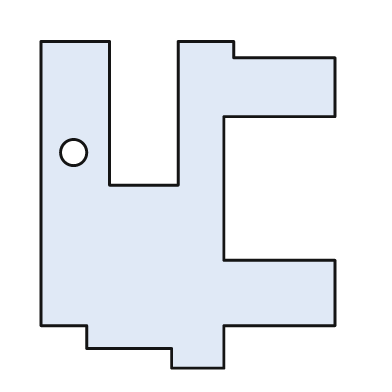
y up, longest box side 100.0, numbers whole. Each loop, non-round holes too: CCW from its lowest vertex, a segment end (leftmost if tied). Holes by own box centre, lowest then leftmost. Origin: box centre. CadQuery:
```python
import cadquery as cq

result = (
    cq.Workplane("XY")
    .moveTo(-5.0, -50.0)
    .lineTo(11.0, -50.0)
    .lineTo(11.0, -37.0)
    .lineTo(45.0, -37.0)
    .lineTo(45.0, -17.0)
    .lineTo(11.0, -17.0)
    .lineTo(11.0, 27.0)
    .lineTo(45.0, 27.0)
    .lineTo(45.0, 45.0)
    .lineTo(14.0, 45.0)
    .lineTo(14.0, 50.0)
    .lineTo(-3.0, 50.0)
    .lineTo(-3.0, 6.0)
    .lineTo(-24.0, 6.0)
    .lineTo(-24.0, 50.0)
    .lineTo(-45.0, 50.0)
    .lineTo(-45.0, -37.0)
    .lineTo(-31.0, -37.0)
    .lineTo(-31.0, -44.0)
    .lineTo(-5.0, -44.0)
    .close()
    .moveTo(-35.0, 16.0)
    .circle(4.0)
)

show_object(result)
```